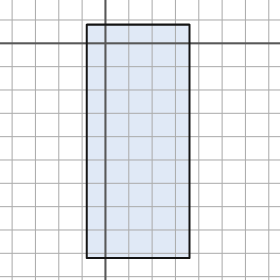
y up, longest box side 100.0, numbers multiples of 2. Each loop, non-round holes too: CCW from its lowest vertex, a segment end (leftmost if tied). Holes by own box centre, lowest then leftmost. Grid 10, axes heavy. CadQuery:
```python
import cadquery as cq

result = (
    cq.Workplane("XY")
    .moveTo(-8.0, -92.0)
    .lineTo(36.0, -92.0)
    .lineTo(36.0, 8.0)
    .lineTo(-8.0, 8.0)
    .close()
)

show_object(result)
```